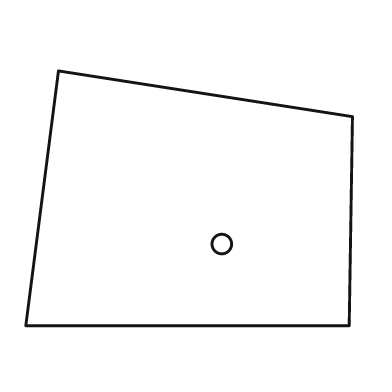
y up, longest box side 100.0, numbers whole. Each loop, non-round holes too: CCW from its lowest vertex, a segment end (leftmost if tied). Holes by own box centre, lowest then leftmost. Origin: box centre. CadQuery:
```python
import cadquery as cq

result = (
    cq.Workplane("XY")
    .moveTo(-50.0, -39.0)
    .lineTo(49.0, -39.0)
    .lineTo(50.0, 25.0)
    .lineTo(-40.0, 39.0)
    .close()
    .moveTo(10.0, -14.0)
    .circle(3.0)
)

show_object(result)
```